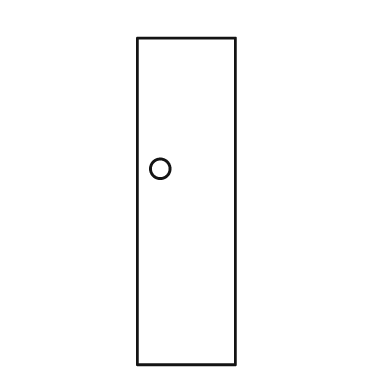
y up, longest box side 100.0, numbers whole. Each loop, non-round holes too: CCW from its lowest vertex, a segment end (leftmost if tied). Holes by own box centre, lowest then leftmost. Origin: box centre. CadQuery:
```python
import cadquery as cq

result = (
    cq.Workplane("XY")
    .moveTo(-15.0, -50.0)
    .lineTo(15.0, -50.0)
    .lineTo(15.0, 50.0)
    .lineTo(-15.0, 50.0)
    .close()
    .moveTo(-8.0, 10.0)
    .circle(3.0)
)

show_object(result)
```